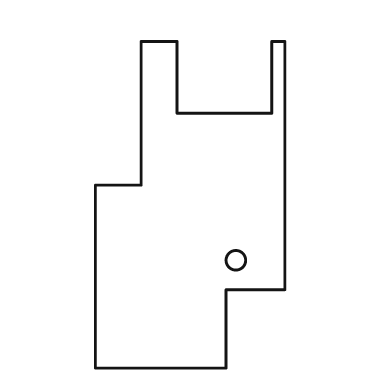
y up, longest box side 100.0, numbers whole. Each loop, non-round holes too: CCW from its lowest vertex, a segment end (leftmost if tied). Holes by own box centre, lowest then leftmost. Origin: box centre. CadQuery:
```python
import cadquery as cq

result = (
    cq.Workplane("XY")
    .moveTo(-29.0, -50.0)
    .lineTo(11.0, -50.0)
    .lineTo(11.0, -26.0)
    .lineTo(29.0, -26.0)
    .lineTo(29.0, 50.0)
    .lineTo(25.0, 50.0)
    .lineTo(25.0, 28.0)
    .lineTo(-4.0, 28.0)
    .lineTo(-4.0, 50.0)
    .lineTo(-15.0, 50.0)
    .lineTo(-15.0, 6.0)
    .lineTo(-29.0, 6.0)
    .close()
    .moveTo(14.0, -17.0)
    .circle(3.0)
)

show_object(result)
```